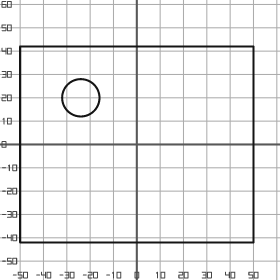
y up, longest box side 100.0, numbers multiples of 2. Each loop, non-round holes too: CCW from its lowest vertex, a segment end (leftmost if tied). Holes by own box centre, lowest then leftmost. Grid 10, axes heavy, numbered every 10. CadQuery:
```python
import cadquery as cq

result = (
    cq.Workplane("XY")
    .moveTo(-50.0, -42.0)
    .lineTo(50.0, -42.0)
    .lineTo(50.0, 42.0)
    .lineTo(-50.0, 42.0)
    .close()
    .moveTo(-24.0, 20.0)
    .circle(8.0)
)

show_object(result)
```